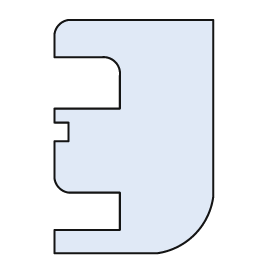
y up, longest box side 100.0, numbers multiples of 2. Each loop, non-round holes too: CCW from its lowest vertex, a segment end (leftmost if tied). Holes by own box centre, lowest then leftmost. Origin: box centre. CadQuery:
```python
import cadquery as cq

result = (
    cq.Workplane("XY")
    .moveTo(-34.0, -50.0)
    .lineTo(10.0, -50.0)
    .threePointArc((26.0, -42.0), (34.0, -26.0))
    .lineTo(34.0, 50.0)
    .lineTo(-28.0, 50.0)
    .threePointArc((-32.0, 48.0), (-34.0, 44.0))
    .lineTo(-34.0, 34.0)
    .lineTo(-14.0, 34.0)
    .threePointArc((-8.0, 32.0), (-6.0, 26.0))
    .lineTo(-6.0, 12.0)
    .lineTo(-34.0, 12.0)
    .lineTo(-34.0, 6.0)
    .lineTo(-28.0, 6.0)
    .lineTo(-28.0, -2.0)
    .lineTo(-34.0, -2.0)
    .lineTo(-34.0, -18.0)
    .threePointArc((-32.0, -22.0), (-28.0, -24.0))
    .lineTo(-6.0, -24.0)
    .lineTo(-6.0, -40.0)
    .lineTo(-34.0, -40.0)
    .close()
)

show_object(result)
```